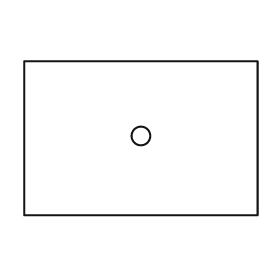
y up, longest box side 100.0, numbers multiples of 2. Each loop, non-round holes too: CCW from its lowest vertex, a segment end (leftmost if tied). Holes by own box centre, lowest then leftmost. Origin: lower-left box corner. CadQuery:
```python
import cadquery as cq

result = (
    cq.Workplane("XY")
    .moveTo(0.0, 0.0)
    .lineTo(100.0, 0.0)
    .lineTo(100.0, 66.0)
    .lineTo(0.0, 66.0)
    .close()
    .moveTo(50.0, 34.0)
    .circle(4.0)
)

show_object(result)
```